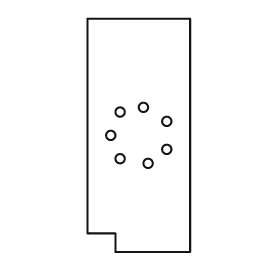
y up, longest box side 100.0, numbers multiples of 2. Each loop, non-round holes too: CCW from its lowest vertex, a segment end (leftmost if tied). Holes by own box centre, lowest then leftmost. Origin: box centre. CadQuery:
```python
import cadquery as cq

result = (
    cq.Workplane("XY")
    .moveTo(-10.0, -50.0)
    .lineTo(22.0, -50.0)
    .lineTo(22.0, 50.0)
    .lineTo(-22.0, 50.0)
    .lineTo(-22.0, -42.0)
    .lineTo(-10.0, -42.0)
    .close()
    .moveTo(4.0, -12.0)
    .circle(2.0)
    .moveTo(-8.0, -10.0)
    .circle(2.0)
    .moveTo(12.0, -6.0)
    .circle(2.0)
    .moveTo(-12.0, 0.0)
    .circle(2.0)
    .moveTo(12.0, 6.0)
    .circle(2.0)
    .moveTo(-8.0, 10.0)
    .circle(2.0)
    .moveTo(2.0, 12.0)
    .circle(2.0)
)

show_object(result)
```